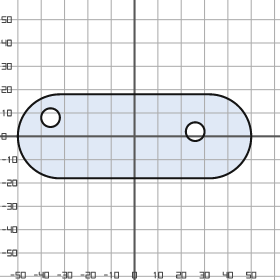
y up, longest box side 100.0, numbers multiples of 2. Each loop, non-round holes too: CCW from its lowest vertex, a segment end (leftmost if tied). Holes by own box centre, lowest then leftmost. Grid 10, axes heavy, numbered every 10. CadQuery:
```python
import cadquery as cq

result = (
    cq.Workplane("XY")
    .moveTo(-32.0, -18.0)
    .lineTo(32.0, -18.0)
    .threePointArc((50.0, 0.0), (32.0, 18.0))
    .lineTo(-32.0, 18.0)
    .threePointArc((-50.0, 0.0), (-32.0, -18.0))
    .close()
    .moveTo(26.0, 2.0)
    .circle(4.0)
    .moveTo(-36.0, 8.0)
    .circle(4.0)
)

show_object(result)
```